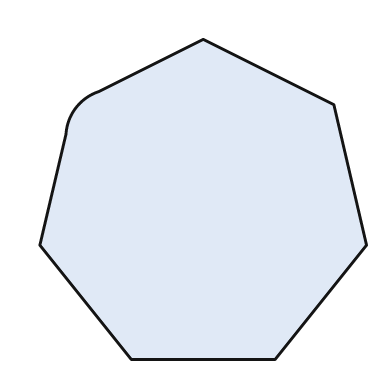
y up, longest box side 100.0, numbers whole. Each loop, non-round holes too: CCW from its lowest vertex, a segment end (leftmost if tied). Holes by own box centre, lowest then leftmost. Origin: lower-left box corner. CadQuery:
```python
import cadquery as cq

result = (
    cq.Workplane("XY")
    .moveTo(28.0, 0.0)
    .lineTo(72.0, 0.0)
    .lineTo(100.0, 35.0)
    .lineTo(90.0, 78.0)
    .lineTo(50.0, 98.0)
    .lineTo(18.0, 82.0)
    .threePointArc((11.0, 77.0), (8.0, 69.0))
    .lineTo(0.0, 35.0)
    .close()
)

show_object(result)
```